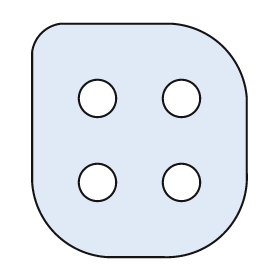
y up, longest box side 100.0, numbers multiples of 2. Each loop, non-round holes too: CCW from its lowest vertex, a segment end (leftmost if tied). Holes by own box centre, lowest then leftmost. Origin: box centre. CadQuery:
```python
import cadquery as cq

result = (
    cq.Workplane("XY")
    .moveTo(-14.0, -50.0)
    .lineTo(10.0, -50.0)
    .threePointArc((36.0, -40.0), (46.0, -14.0))
    .lineTo(46.0, 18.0)
    .threePointArc((36.0, 40.0), (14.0, 50.0))
    .lineTo(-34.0, 50.0)
    .threePointArc((-42.0, 46.0), (-46.0, 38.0))
    .lineTo(-46.0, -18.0)
    .threePointArc((-36.0, -40.0), (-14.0, -50.0))
    .close()
    .moveTo(-18.0, -18.0)
    .circle(8.0)
    .moveTo(18.0, -18.0)
    .circle(8.0)
    .moveTo(-18.0, 18.0)
    .circle(8.0)
    .moveTo(18.0, 18.0)
    .circle(8.0)
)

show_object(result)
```